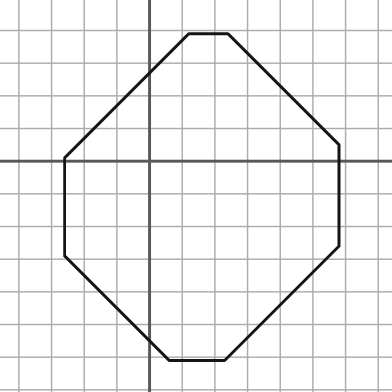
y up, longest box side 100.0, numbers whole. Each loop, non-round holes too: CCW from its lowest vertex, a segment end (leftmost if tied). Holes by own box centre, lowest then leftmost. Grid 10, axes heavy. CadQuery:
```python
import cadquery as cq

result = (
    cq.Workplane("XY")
    .moveTo(6.0, -61.0)
    .lineTo(23.0, -61.0)
    .lineTo(58.0, -26.0)
    .lineTo(58.0, 5.0)
    .lineTo(24.0, 39.0)
    .lineTo(12.0, 39.0)
    .lineTo(-26.0, 1.0)
    .lineTo(-26.0, -29.0)
    .close()
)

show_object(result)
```